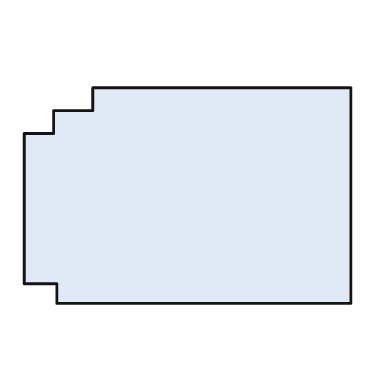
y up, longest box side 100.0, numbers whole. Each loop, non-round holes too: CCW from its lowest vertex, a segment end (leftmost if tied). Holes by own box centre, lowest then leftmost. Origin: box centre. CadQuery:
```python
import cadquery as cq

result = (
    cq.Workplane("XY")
    .moveTo(-40.0, -33.0)
    .lineTo(50.0, -33.0)
    .lineTo(50.0, 33.0)
    .lineTo(-29.0, 33.0)
    .lineTo(-29.0, 26.0)
    .lineTo(-41.0, 26.0)
    .lineTo(-41.0, 19.0)
    .lineTo(-50.0, 19.0)
    .lineTo(-50.0, -27.0)
    .lineTo(-40.0, -27.0)
    .close()
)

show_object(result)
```